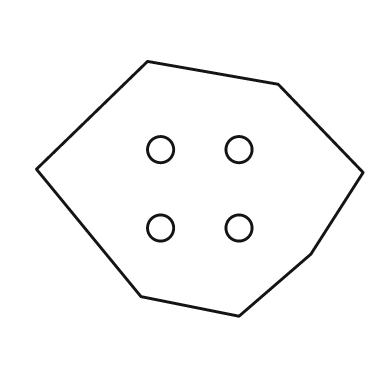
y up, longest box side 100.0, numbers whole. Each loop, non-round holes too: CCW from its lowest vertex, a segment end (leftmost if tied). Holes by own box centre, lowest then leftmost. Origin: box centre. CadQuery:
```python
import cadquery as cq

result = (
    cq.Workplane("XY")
    .moveTo(12.0, -39.0)
    .lineTo(34.0, -20.0)
    .lineTo(50.0, 5.0)
    .lineTo(24.0, 32.0)
    .lineTo(-16.0, 39.0)
    .lineTo(-50.0, 6.0)
    .lineTo(-18.0, -33.0)
    .close()
    .moveTo(-12.0, -12.0)
    .circle(4.0)
    .moveTo(12.0, -12.0)
    .circle(4.0)
    .moveTo(-12.0, 12.0)
    .circle(4.0)
    .moveTo(12.0, 12.0)
    .circle(4.0)
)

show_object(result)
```